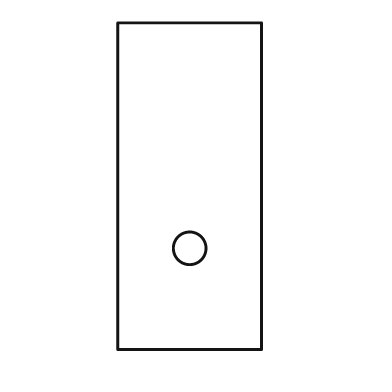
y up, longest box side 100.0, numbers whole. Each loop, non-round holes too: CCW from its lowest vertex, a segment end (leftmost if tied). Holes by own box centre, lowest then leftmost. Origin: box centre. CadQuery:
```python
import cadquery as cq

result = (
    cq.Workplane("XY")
    .moveTo(-22.0, -50.0)
    .lineTo(22.0, -50.0)
    .lineTo(22.0, 50.0)
    .lineTo(-22.0, 50.0)
    .close()
    .moveTo(0.0, -19.0)
    .circle(5.0)
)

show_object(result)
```